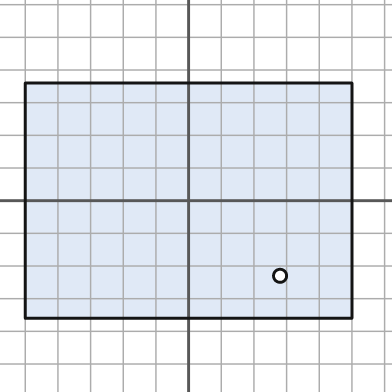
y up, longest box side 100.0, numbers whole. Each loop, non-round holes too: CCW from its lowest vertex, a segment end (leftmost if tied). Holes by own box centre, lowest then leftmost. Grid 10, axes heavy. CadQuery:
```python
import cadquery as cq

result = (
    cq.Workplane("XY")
    .moveTo(-50.0, -36.0)
    .lineTo(50.0, -36.0)
    .lineTo(50.0, 36.0)
    .lineTo(-50.0, 36.0)
    .close()
    .moveTo(28.0, -23.0)
    .circle(2.0)
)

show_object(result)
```